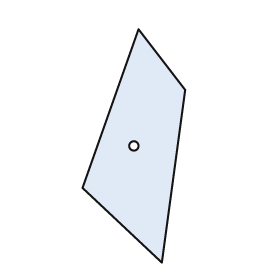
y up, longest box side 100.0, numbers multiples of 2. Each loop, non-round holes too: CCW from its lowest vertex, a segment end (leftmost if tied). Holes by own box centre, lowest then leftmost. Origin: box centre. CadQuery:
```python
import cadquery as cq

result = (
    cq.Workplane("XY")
    .moveTo(12.0, -50.0)
    .lineTo(22.0, 24.0)
    .lineTo(2.0, 50.0)
    .lineTo(-22.0, -18.0)
    .close()
    .moveTo(0.0, 0.0)
    .circle(2.0)
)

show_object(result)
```